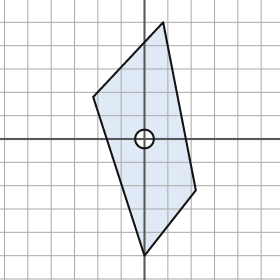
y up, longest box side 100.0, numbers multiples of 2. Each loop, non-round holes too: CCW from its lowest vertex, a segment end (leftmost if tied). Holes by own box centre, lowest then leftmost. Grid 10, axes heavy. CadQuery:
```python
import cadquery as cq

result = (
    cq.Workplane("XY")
    .moveTo(0.0, -50.0)
    .lineTo(22.0, -22.0)
    .lineTo(8.0, 50.0)
    .lineTo(-22.0, 18.0)
    .close()
    .moveTo(0.0, 0.0)
    .circle(4.0)
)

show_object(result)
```